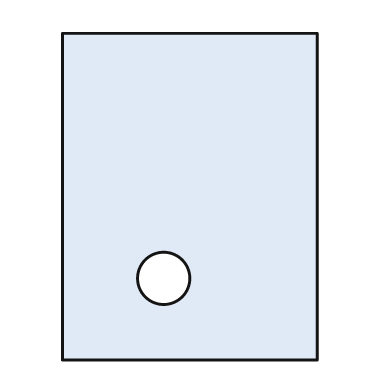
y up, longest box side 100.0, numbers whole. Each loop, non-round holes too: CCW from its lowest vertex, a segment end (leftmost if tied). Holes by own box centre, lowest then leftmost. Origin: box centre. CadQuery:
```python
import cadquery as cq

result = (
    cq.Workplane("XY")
    .moveTo(-39.0, -50.0)
    .lineTo(39.0, -50.0)
    .lineTo(39.0, 50.0)
    .lineTo(-39.0, 50.0)
    .close()
    .moveTo(-8.0, -25.0)
    .circle(8.0)
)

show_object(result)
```